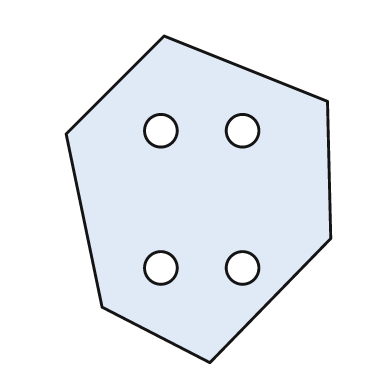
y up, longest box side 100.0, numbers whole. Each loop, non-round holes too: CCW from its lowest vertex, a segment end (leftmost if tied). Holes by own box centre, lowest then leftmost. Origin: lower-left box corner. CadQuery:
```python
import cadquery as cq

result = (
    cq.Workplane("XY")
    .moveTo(44.0, 0.0)
    .lineTo(81.0, 38.0)
    .lineTo(80.0, 80.0)
    .lineTo(30.0, 100.0)
    .lineTo(0.0, 70.0)
    .lineTo(11.0, 17.0)
    .close()
    .moveTo(29.0, 29.0)
    .circle(5.0)
    .moveTo(54.0, 29.0)
    .circle(5.0)
    .moveTo(29.0, 71.0)
    .circle(5.0)
    .moveTo(54.0, 71.0)
    .circle(5.0)
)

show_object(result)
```